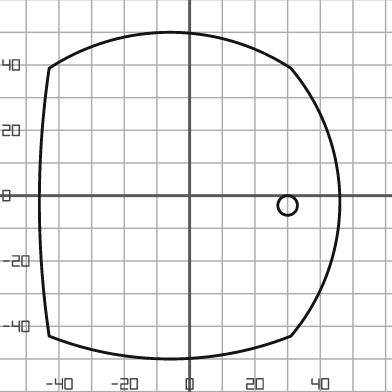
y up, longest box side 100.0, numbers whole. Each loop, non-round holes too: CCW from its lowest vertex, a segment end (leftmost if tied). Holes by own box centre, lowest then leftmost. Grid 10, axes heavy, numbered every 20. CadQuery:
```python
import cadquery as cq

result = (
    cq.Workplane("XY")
    .moveTo(-43.0, -43.0)
    .threePointArc((-6.0, -50.0), (31.0, -43.0))
    .threePointArc((46.0, -2.0), (31.0, 39.0))
    .threePointArc((-6.0, 50.0), (-43.0, 39.0))
    .threePointArc((-46.0, -2.0), (-43.0, -43.0))
    .close()
    .moveTo(30.0, -3.0)
    .circle(3.0)
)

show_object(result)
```